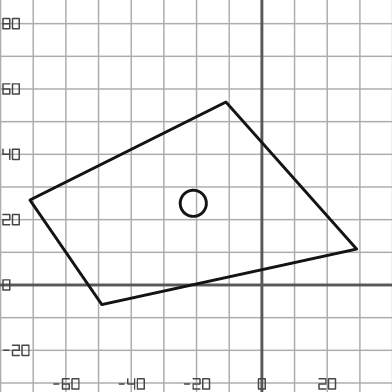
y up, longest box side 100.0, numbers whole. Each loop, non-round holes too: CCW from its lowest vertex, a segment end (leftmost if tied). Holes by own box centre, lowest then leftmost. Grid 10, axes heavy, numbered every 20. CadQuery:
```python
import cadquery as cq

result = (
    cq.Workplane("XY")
    .moveTo(-49.0, -6.0)
    .lineTo(29.0, 11.0)
    .lineTo(-11.0, 56.0)
    .lineTo(-71.0, 26.0)
    .close()
    .moveTo(-21.0, 25.0)
    .circle(4.0)
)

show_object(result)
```